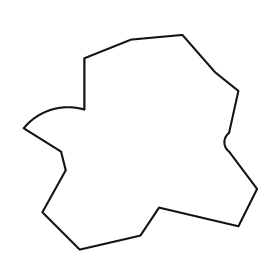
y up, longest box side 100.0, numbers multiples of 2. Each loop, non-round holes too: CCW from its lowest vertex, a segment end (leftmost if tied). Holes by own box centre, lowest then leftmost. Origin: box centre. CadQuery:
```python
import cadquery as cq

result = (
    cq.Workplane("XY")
    .moveTo(-26.0, -46.0)
    .lineTo(0.0, -40.0)
    .lineTo(8.0, -28.0)
    .lineTo(42.0, -36.0)
    .lineTo(50.0, -20.0)
    .lineTo(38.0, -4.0)
    .threePointArc((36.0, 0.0), (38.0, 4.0))
    .lineTo(42.0, 22.0)
    .lineTo(32.0, 30.0)
    .lineTo(18.0, 46.0)
    .lineTo(-4.0, 44.0)
    .lineTo(-24.0, 36.0)
    .lineTo(-24.0, 14.0)
    .threePointArc((-38.0, 14.0), (-50.0, 6.0))
    .lineTo(-34.0, -4.0)
    .lineTo(-32.0, -12.0)
    .lineTo(-42.0, -30.0)
    .close()
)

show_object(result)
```